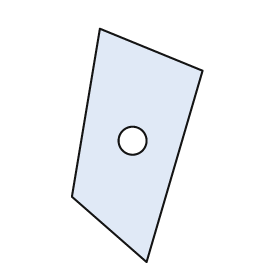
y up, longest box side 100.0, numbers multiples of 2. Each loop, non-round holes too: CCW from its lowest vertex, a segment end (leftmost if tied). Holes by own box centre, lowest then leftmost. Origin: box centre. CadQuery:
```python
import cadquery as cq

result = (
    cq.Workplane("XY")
    .moveTo(4.0, -50.0)
    .lineTo(28.0, 32.0)
    .lineTo(-16.0, 50.0)
    .lineTo(-28.0, -22.0)
    .close()
    .moveTo(-2.0, 2.0)
    .circle(6.0)
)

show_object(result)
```